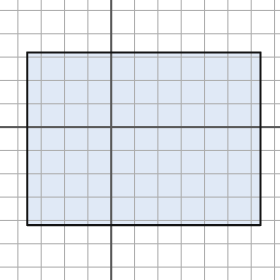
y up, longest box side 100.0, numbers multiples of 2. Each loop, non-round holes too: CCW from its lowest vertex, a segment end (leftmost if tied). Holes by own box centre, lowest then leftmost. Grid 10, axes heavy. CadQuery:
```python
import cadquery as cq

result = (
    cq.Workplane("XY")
    .moveTo(-36.0, -42.0)
    .lineTo(64.0, -42.0)
    .lineTo(64.0, 32.0)
    .lineTo(-36.0, 32.0)
    .close()
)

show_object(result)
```